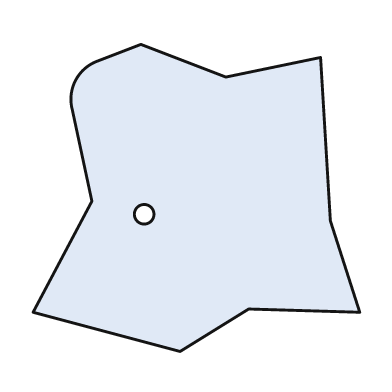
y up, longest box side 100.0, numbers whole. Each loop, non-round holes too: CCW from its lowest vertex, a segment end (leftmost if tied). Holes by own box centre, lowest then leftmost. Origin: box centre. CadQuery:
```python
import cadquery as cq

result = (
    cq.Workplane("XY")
    .moveTo(-5.0, -47.0)
    .lineTo(16.0, -34.0)
    .lineTo(50.0, -35.0)
    .lineTo(41.0, -7.0)
    .lineTo(38.0, 43.0)
    .lineTo(9.0, 37.0)
    .lineTo(-17.0, 47.0)
    .lineTo(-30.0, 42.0)
    .threePointArc((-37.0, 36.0), (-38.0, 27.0))
    .lineTo(-32.0, -1.0)
    .lineTo(-50.0, -35.0)
    .close()
    .moveTo(-16.0, -5.0)
    .circle(3.0)
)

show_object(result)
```